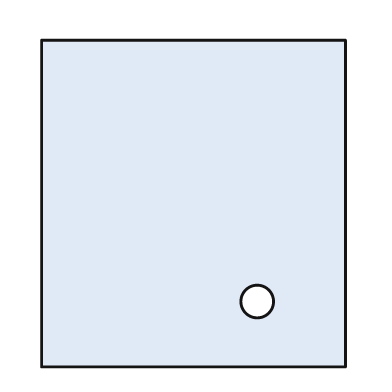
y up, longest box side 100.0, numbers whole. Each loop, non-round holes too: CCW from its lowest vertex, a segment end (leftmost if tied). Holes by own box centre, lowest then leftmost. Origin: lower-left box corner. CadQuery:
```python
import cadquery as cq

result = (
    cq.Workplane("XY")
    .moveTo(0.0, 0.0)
    .lineTo(93.0, 0.0)
    .lineTo(93.0, 100.0)
    .lineTo(0.0, 100.0)
    .close()
    .moveTo(66.0, 20.0)
    .circle(5.0)
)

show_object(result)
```